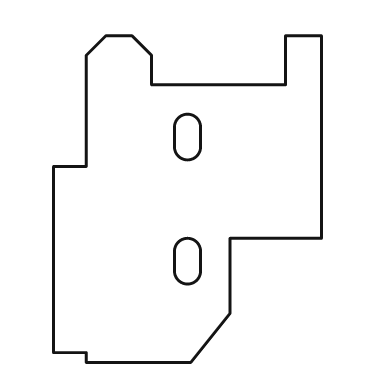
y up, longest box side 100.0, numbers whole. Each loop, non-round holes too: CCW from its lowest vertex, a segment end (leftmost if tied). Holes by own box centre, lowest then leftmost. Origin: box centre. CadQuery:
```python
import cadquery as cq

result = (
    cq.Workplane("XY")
    .moveTo(-31.0, -50.0)
    .lineTo(1.0, -50.0)
    .lineTo(13.0, -35.0)
    .lineTo(13.0, -12.0)
    .lineTo(41.0, -12.0)
    .lineTo(41.0, 50.0)
    .lineTo(30.0, 50.0)
    .lineTo(30.0, 35.0)
    .lineTo(-11.0, 35.0)
    .lineTo(-11.0, 44.0)
    .lineTo(-17.0, 50.0)
    .lineTo(-25.0, 50.0)
    .lineTo(-31.0, 44.0)
    .lineTo(-31.0, 10.0)
    .lineTo(-41.0, 10.0)
    .lineTo(-41.0, -47.0)
    .lineTo(-31.0, -47.0)
    .close()
    .moveTo(-4.0, -22.0)
    .threePointArc((0.0, -26.0), (4.0, -22.0))
    .lineTo(4.0, -16.0)
    .threePointArc((0.0, -12.0), (-4.0, -16.0))
    .close()
    .moveTo(-4.0, 16.0)
    .threePointArc((0.0, 12.0), (4.0, 16.0))
    .lineTo(4.0, 22.0)
    .threePointArc((0.0, 26.0), (-4.0, 22.0))
    .close()
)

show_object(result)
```